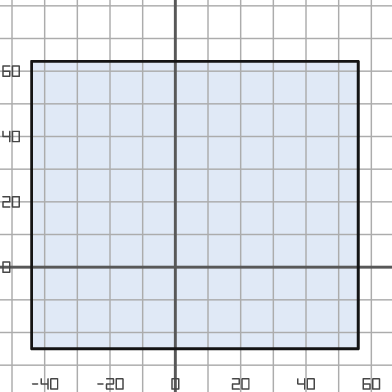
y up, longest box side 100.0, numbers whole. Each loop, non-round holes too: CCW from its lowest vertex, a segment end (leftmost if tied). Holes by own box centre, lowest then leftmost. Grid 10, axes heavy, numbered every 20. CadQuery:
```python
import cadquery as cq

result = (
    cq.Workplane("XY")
    .moveTo(-44.0, -25.0)
    .lineTo(56.0, -25.0)
    .lineTo(56.0, 63.0)
    .lineTo(-44.0, 63.0)
    .close()
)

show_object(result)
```